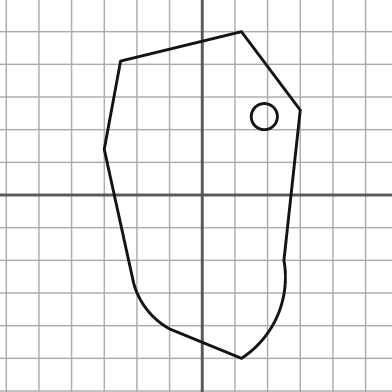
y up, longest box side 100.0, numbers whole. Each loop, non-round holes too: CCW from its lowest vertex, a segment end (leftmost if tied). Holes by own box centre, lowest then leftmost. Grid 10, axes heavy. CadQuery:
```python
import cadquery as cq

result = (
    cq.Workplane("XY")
    .moveTo(12.0, -50.0)
    .threePointArc((23.0, -37.0), (25.0, -20.0))
    .lineTo(30.0, 26.0)
    .lineTo(12.0, 50.0)
    .lineTo(-25.0, 41.0)
    .lineTo(-30.0, 14.0)
    .lineTo(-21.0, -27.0)
    .threePointArc((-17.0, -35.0), (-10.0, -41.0))
    .close()
    .moveTo(19.0, 24.0)
    .circle(4.0)
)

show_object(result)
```